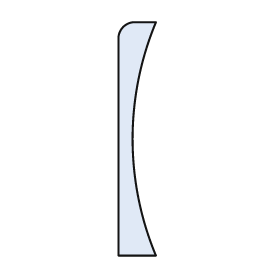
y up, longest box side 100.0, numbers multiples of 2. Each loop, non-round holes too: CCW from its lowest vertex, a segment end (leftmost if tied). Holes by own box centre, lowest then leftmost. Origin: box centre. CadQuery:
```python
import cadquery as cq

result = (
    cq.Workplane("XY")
    .moveTo(-8.0, -50.0)
    .lineTo(8.0, -50.0)
    .threePointArc((-2.0, 0.0), (8.0, 50.0))
    .lineTo(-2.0, 50.0)
    .threePointArc((-6.0, 48.0), (-8.0, 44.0))
    .close()
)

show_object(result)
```